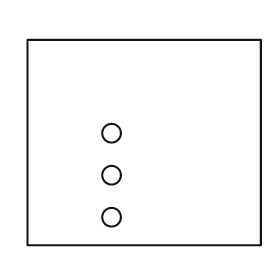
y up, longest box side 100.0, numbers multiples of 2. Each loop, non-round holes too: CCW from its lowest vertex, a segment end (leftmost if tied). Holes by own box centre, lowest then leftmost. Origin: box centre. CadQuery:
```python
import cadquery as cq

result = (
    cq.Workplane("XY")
    .moveTo(-50.0, -44.0)
    .lineTo(50.0, -44.0)
    .lineTo(50.0, 44.0)
    .lineTo(-50.0, 44.0)
    .close()
    .moveTo(-14.0, -32.0)
    .circle(4.0)
    .moveTo(-14.0, -14.0)
    .circle(4.0)
    .moveTo(-14.0, 4.0)
    .circle(4.0)
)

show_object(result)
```